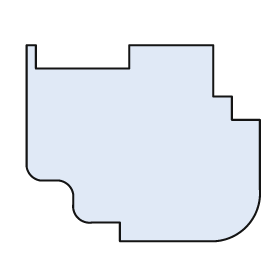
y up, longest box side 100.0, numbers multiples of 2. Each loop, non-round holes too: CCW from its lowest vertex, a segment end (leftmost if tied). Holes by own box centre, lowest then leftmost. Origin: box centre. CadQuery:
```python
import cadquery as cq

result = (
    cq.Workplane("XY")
    .moveTo(-10.0, -42.0)
    .lineTo(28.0, -42.0)
    .threePointArc((44.0, -36.0), (50.0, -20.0))
    .lineTo(50.0, 10.0)
    .lineTo(38.0, 10.0)
    .lineTo(38.0, 20.0)
    .lineTo(30.0, 20.0)
    .lineTo(30.0, 42.0)
    .lineTo(-6.0, 42.0)
    .lineTo(-6.0, 32.0)
    .lineTo(-46.0, 32.0)
    .lineTo(-46.0, 42.0)
    .lineTo(-50.0, 42.0)
    .lineTo(-50.0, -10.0)
    .threePointArc((-48.0, -14.0), (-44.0, -16.0))
    .lineTo(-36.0, -16.0)
    .threePointArc((-32.0, -18.0), (-30.0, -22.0))
    .lineTo(-30.0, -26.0)
    .threePointArc((-28.0, -32.0), (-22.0, -34.0))
    .lineTo(-10.0, -34.0)
    .close()
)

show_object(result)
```